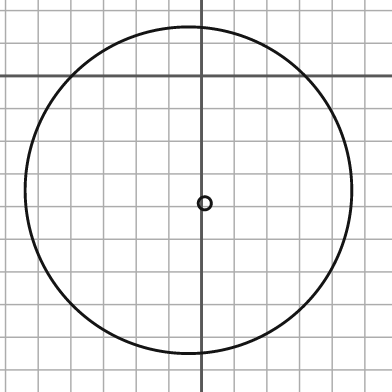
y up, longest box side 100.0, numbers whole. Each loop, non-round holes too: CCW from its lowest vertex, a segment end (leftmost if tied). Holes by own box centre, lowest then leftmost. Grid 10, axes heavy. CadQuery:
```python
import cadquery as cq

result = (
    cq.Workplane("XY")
    .moveTo(-4.0, -35.0)
    .circle(50.0)
    .moveTo(1.0, -39.0)
    .circle(2.0)
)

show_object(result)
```